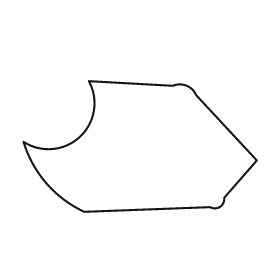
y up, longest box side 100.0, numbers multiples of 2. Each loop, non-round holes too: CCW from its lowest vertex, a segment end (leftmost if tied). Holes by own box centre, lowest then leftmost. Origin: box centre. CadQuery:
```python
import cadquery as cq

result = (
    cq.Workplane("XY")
    .moveTo(-24.0, -28.0)
    .lineTo(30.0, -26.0)
    .threePointArc((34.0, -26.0), (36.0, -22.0))
    .lineTo(50.0, -6.0)
    .lineTo(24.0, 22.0)
    .threePointArc((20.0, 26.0), (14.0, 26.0))
    .lineTo(-22.0, 28.0)
    .threePointArc((-26.0, 4.0), (-50.0, 2.0))
    .threePointArc((-40.0, -16.0), (-24.0, -28.0))
    .close()
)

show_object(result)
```